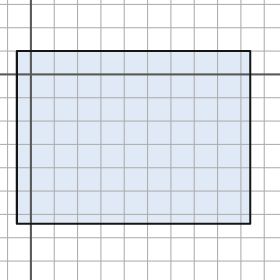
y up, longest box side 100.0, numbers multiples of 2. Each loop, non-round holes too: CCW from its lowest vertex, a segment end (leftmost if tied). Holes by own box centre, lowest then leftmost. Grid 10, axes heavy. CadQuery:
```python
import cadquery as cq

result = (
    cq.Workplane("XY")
    .moveTo(-6.0, -64.0)
    .lineTo(94.0, -64.0)
    .lineTo(94.0, 10.0)
    .lineTo(-6.0, 10.0)
    .close()
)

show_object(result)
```